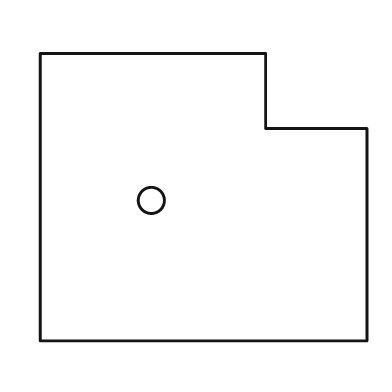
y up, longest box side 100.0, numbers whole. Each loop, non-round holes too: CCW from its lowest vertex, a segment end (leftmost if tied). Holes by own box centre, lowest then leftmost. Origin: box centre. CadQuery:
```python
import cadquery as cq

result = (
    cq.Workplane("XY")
    .moveTo(-50.0, -44.0)
    .lineTo(50.0, -44.0)
    .lineTo(50.0, 21.0)
    .lineTo(19.0, 21.0)
    .lineTo(19.0, 44.0)
    .lineTo(-50.0, 44.0)
    .close()
    .moveTo(-16.0, -1.0)
    .circle(4.0)
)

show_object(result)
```